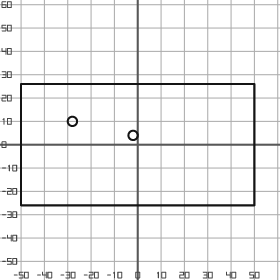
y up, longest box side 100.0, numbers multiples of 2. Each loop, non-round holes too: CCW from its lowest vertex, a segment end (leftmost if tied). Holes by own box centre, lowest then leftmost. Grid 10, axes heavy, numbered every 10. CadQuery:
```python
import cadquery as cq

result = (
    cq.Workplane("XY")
    .moveTo(-50.0, -26.0)
    .lineTo(50.0, -26.0)
    .lineTo(50.0, 26.0)
    .lineTo(-50.0, 26.0)
    .close()
    .moveTo(-2.0, 4.0)
    .circle(2.0)
    .moveTo(-28.0, 10.0)
    .circle(2.0)
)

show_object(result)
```